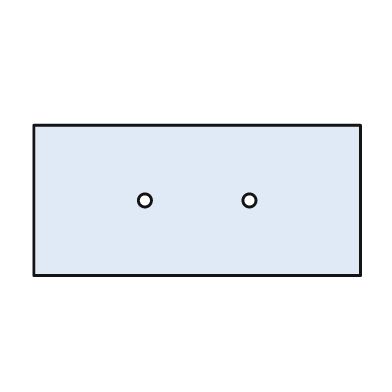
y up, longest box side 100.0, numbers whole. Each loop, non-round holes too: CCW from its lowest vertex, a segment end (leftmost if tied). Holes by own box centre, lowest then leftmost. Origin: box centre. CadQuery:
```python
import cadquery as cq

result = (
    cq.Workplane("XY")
    .moveTo(-50.0, -23.0)
    .lineTo(50.0, -23.0)
    .lineTo(50.0, 23.0)
    .lineTo(-50.0, 23.0)
    .close()
    .moveTo(-16.0, 0.0)
    .circle(2.0)
    .moveTo(16.0, 0.0)
    .circle(2.0)
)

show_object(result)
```